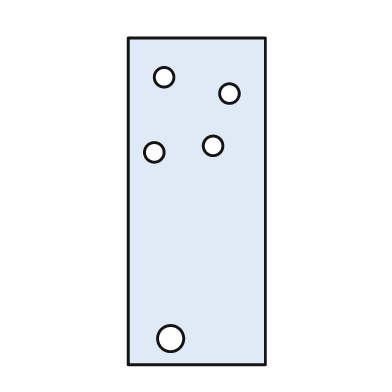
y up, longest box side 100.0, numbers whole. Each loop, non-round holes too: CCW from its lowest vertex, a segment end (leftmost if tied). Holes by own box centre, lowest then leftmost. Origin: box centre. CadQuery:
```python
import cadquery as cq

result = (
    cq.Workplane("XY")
    .moveTo(-21.0, -50.0)
    .lineTo(21.0, -50.0)
    .lineTo(21.0, 50.0)
    .lineTo(-21.0, 50.0)
    .close()
    .moveTo(-8.0, -42.0)
    .circle(4.0)
    .moveTo(-13.0, 15.0)
    .circle(3.0)
    .moveTo(5.0, 17.0)
    .circle(3.0)
    .moveTo(10.0, 33.0)
    .circle(3.0)
    .moveTo(-10.0, 38.0)
    .circle(3.0)
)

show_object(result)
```